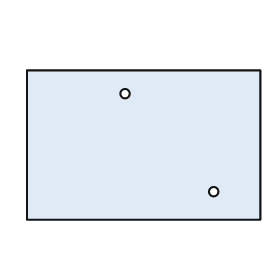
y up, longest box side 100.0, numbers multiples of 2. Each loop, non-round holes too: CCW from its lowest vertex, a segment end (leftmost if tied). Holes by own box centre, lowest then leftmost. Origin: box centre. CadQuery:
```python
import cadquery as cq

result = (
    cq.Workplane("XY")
    .moveTo(-50.0, -32.0)
    .lineTo(50.0, -32.0)
    .lineTo(50.0, 32.0)
    .lineTo(-50.0, 32.0)
    .close()
    .moveTo(30.0, -20.0)
    .circle(2.0)
    .moveTo(-8.0, 22.0)
    .circle(2.0)
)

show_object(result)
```